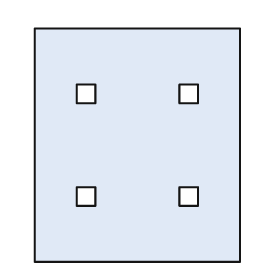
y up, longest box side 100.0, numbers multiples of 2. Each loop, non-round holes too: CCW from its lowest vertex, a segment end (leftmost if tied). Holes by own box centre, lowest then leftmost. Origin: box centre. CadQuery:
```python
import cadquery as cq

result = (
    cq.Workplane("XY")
    .moveTo(-44.0, -50.0)
    .lineTo(44.0, -50.0)
    .lineTo(44.0, 50.0)
    .lineTo(-44.0, 50.0)
    .close()
    .moveTo(-26.0, -26.0)
    .lineTo(-18.0, -26.0)
    .lineTo(-18.0, -18.0)
    .lineTo(-26.0, -18.0)
    .close()
    .moveTo(18.0, -26.0)
    .lineTo(26.0, -26.0)
    .lineTo(26.0, -18.0)
    .lineTo(18.0, -18.0)
    .close()
    .moveTo(-26.0, 18.0)
    .lineTo(-18.0, 18.0)
    .lineTo(-18.0, 26.0)
    .lineTo(-26.0, 26.0)
    .close()
    .moveTo(18.0, 18.0)
    .lineTo(26.0, 18.0)
    .lineTo(26.0, 26.0)
    .lineTo(18.0, 26.0)
    .close()
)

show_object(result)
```